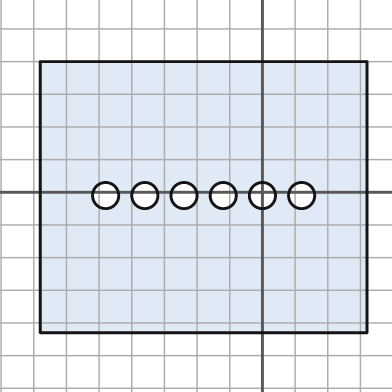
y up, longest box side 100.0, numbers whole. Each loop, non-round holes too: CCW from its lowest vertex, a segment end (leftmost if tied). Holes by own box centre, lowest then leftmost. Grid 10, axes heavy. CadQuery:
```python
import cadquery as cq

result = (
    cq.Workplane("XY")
    .moveTo(-68.0, -43.0)
    .lineTo(32.0, -43.0)
    .lineTo(32.0, 40.0)
    .lineTo(-68.0, 40.0)
    .close()
    .moveTo(-48.0, -1.0)
    .circle(4.0)
    .moveTo(-36.0, -1.0)
    .circle(4.0)
    .moveTo(-24.0, -1.0)
    .circle(4.0)
    .moveTo(-12.0, -1.0)
    .circle(4.0)
    .moveTo(0.0, -1.0)
    .circle(4.0)
    .moveTo(12.0, -1.0)
    .circle(4.0)
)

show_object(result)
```